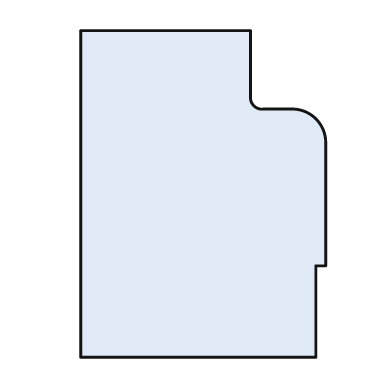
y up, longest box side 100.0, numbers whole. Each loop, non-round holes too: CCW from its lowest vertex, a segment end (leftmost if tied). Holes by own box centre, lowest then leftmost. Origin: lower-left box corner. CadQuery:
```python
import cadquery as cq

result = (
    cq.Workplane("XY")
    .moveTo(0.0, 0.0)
    .lineTo(72.0, 0.0)
    .lineTo(72.0, 28.0)
    .lineTo(75.0, 28.0)
    .lineTo(75.0, 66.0)
    .threePointArc((72.0, 73.0), (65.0, 76.0))
    .lineTo(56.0, 76.0)
    .threePointArc((53.0, 77.0), (52.0, 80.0))
    .lineTo(52.0, 100.0)
    .lineTo(0.0, 100.0)
    .close()
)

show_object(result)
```